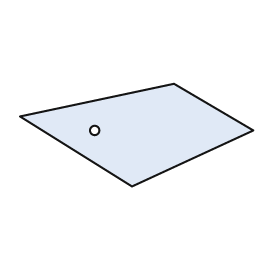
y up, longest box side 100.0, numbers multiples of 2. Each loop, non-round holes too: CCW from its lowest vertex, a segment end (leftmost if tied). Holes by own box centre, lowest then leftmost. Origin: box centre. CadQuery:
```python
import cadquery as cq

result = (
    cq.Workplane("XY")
    .moveTo(-2.0, -22.0)
    .lineTo(50.0, 2.0)
    .lineTo(16.0, 22.0)
    .lineTo(-50.0, 8.0)
    .close()
    .moveTo(-18.0, 2.0)
    .circle(2.0)
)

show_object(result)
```